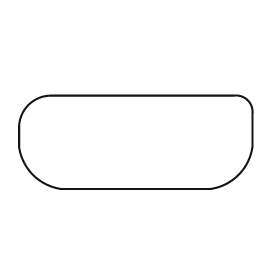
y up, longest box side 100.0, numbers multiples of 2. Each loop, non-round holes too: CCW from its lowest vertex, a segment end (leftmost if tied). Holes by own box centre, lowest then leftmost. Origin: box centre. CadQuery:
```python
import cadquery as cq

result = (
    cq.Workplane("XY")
    .moveTo(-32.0, -20.0)
    .lineTo(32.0, -20.0)
    .threePointArc((44.0, -14.0), (50.0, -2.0))
    .lineTo(50.0, 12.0)
    .threePointArc((48.0, 18.0), (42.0, 20.0))
    .lineTo(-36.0, 20.0)
    .threePointArc((-46.0, 16.0), (-50.0, 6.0))
    .lineTo(-50.0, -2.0)
    .threePointArc((-44.0, -14.0), (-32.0, -20.0))
    .close()
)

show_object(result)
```